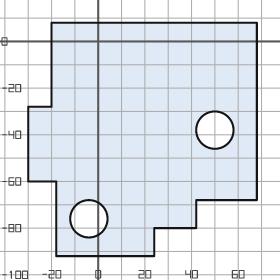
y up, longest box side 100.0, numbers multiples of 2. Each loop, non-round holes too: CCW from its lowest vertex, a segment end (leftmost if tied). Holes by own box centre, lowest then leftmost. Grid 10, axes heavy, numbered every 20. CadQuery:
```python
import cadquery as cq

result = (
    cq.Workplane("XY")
    .moveTo(-18.0, -92.0)
    .lineTo(24.0, -92.0)
    .lineTo(24.0, -80.0)
    .lineTo(42.0, -80.0)
    .lineTo(42.0, -68.0)
    .lineTo(68.0, -68.0)
    .lineTo(68.0, 8.0)
    .lineTo(-20.0, 8.0)
    .lineTo(-20.0, -28.0)
    .lineTo(-30.0, -28.0)
    .lineTo(-30.0, -60.0)
    .lineTo(-18.0, -60.0)
    .close()
    .moveTo(-4.0, -76.0)
    .circle(8.0)
    .moveTo(50.0, -38.0)
    .circle(8.0)
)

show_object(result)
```